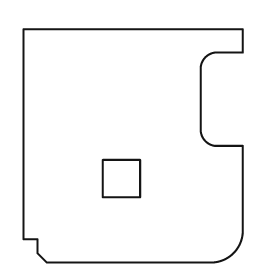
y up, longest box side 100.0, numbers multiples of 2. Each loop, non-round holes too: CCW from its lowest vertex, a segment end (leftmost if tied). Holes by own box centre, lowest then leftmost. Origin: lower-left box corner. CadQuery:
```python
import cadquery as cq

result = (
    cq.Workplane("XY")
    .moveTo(10.0, 0.0)
    .lineTo(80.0, 0.0)
    .threePointArc((90.0, 4.0), (94.0, 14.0))
    .lineTo(94.0, 50.0)
    .lineTo(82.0, 50.0)
    .threePointArc((78.0, 52.0), (76.0, 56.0))
    .lineTo(76.0, 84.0)
    .threePointArc((78.0, 88.0), (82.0, 90.0))
    .lineTo(94.0, 90.0)
    .lineTo(94.0, 100.0)
    .lineTo(0.0, 100.0)
    .lineTo(0.0, 10.0)
    .lineTo(6.0, 10.0)
    .lineTo(6.0, 4.0)
    .close()
    .moveTo(34.0, 28.0)
    .lineTo(50.0, 28.0)
    .lineTo(50.0, 44.0)
    .lineTo(34.0, 44.0)
    .close()
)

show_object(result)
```